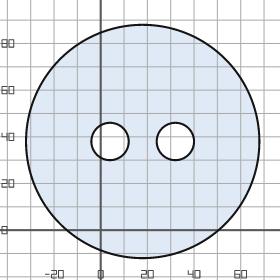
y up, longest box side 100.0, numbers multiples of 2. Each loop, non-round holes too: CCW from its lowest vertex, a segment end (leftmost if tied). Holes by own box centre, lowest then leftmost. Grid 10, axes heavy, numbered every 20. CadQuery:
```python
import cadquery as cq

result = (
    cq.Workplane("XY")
    .moveTo(18.0, 38.0)
    .circle(50.0)
    .moveTo(4.0, 38.0)
    .circle(8.0)
    .moveTo(32.0, 38.0)
    .circle(8.0)
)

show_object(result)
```